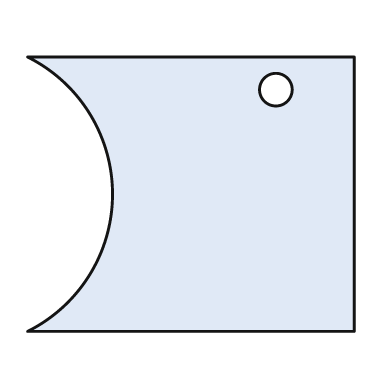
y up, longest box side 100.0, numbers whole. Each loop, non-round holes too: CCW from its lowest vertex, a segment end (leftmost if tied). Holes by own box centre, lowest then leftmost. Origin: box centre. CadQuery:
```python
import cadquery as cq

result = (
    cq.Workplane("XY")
    .moveTo(-50.0, -42.0)
    .lineTo(50.0, -42.0)
    .lineTo(50.0, 42.0)
    .lineTo(-50.0, 42.0)
    .threePointArc((-24.0, 0.0), (-50.0, -42.0))
    .close()
    .moveTo(26.0, 32.0)
    .circle(5.0)
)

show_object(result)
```